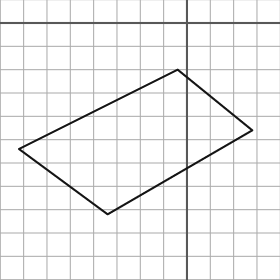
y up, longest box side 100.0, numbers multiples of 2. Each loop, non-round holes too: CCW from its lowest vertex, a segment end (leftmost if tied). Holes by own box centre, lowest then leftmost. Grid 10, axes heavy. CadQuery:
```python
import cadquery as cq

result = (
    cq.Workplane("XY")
    .moveTo(-34.0, -82.0)
    .lineTo(28.0, -46.0)
    .lineTo(-4.0, -20.0)
    .lineTo(-72.0, -54.0)
    .close()
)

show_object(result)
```